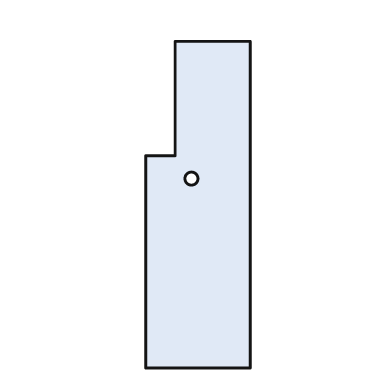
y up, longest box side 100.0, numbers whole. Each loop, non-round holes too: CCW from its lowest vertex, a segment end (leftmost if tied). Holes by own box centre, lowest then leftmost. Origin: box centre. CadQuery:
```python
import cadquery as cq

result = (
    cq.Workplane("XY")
    .moveTo(-16.0, -50.0)
    .lineTo(16.0, -50.0)
    .lineTo(16.0, 50.0)
    .lineTo(-7.0, 50.0)
    .lineTo(-7.0, 15.0)
    .lineTo(-16.0, 15.0)
    .close()
    .moveTo(-2.0, 8.0)
    .circle(2.0)
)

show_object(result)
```